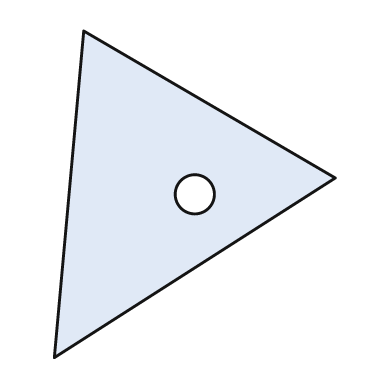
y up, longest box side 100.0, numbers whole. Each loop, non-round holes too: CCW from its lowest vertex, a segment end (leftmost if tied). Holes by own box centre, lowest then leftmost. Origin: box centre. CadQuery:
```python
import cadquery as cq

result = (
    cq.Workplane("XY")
    .moveTo(-43.0, -50.0)
    .lineTo(43.0, 5.0)
    .lineTo(-34.0, 50.0)
    .close()
    .moveTo(0.0, 0.0)
    .circle(6.0)
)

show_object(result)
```